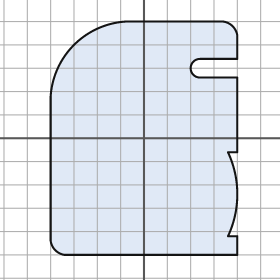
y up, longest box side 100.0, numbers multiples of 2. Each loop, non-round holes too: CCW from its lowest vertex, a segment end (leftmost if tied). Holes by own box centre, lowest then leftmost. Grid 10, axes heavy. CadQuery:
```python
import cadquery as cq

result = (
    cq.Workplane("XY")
    .moveTo(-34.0, -50.0)
    .lineTo(40.0, -50.0)
    .lineTo(40.0, -42.0)
    .lineTo(36.0, -42.0)
    .threePointArc((40.0, -24.0), (36.0, -6.0))
    .lineTo(40.0, -6.0)
    .lineTo(40.0, 26.0)
    .lineTo(24.0, 26.0)
    .threePointArc((20.0, 30.0), (24.0, 34.0))
    .lineTo(40.0, 34.0)
    .lineTo(40.0, 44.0)
    .threePointArc((38.0, 48.0), (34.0, 50.0))
    .lineTo(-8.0, 50.0)
    .threePointArc((-30.0, 40.0), (-40.0, 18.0))
    .lineTo(-40.0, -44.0)
    .threePointArc((-38.0, -48.0), (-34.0, -50.0))
    .close()
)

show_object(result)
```